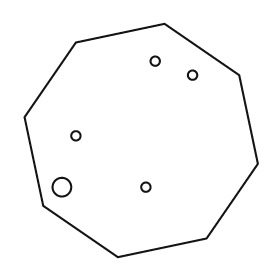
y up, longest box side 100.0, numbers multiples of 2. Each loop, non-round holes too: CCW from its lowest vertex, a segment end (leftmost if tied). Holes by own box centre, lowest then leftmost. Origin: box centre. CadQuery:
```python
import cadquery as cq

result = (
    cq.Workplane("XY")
    .moveTo(-10.0, -50.0)
    .lineTo(28.0, -42.0)
    .lineTo(50.0, -10.0)
    .lineTo(42.0, 28.0)
    .lineTo(10.0, 50.0)
    .lineTo(-28.0, 42.0)
    .lineTo(-50.0, 10.0)
    .lineTo(-42.0, -28.0)
    .close()
    .moveTo(-34.0, -20.0)
    .circle(4.0)
    .moveTo(2.0, -20.0)
    .circle(2.0)
    .moveTo(-28.0, 2.0)
    .circle(2.0)
    .moveTo(22.0, 28.0)
    .circle(2.0)
    .moveTo(6.0, 34.0)
    .circle(2.0)
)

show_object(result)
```